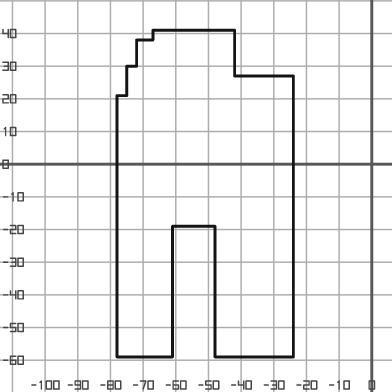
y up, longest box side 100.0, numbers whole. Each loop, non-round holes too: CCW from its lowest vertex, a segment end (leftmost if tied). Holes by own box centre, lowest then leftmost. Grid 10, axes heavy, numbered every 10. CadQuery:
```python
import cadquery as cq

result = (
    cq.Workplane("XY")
    .moveTo(-78.0, -59.0)
    .lineTo(-61.0, -59.0)
    .lineTo(-61.0, -19.0)
    .lineTo(-48.0, -19.0)
    .lineTo(-48.0, -59.0)
    .lineTo(-24.0, -59.0)
    .lineTo(-24.0, 27.0)
    .lineTo(-42.0, 27.0)
    .lineTo(-42.0, 41.0)
    .lineTo(-67.0, 41.0)
    .lineTo(-67.0, 38.0)
    .lineTo(-72.0, 38.0)
    .lineTo(-72.0, 30.0)
    .lineTo(-75.0, 30.0)
    .lineTo(-75.0, 21.0)
    .lineTo(-78.0, 21.0)
    .close()
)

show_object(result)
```